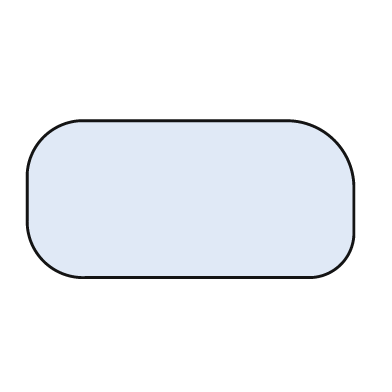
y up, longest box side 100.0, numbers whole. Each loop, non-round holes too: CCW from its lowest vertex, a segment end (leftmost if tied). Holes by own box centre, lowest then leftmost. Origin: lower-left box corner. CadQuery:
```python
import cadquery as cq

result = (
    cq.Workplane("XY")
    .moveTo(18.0, 0.0)
    .lineTo(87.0, 0.0)
    .threePointArc((96.0, 4.0), (100.0, 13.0))
    .lineTo(100.0, 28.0)
    .threePointArc((94.0, 42.0), (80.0, 48.0))
    .lineTo(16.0, 48.0)
    .threePointArc((5.0, 43.0), (0.0, 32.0))
    .lineTo(0.0, 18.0)
    .threePointArc((5.0, 5.0), (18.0, 0.0))
    .close()
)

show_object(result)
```